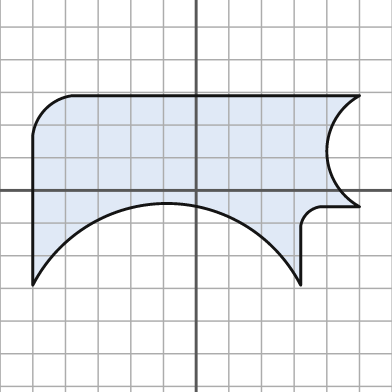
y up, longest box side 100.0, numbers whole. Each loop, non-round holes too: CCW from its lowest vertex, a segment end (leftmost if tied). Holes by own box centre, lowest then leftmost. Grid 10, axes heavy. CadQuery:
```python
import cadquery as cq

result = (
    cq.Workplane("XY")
    .moveTo(-50.0, -29.0)
    .threePointArc((-9.0, -4.0), (32.0, -29.0))
    .lineTo(32.0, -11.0)
    .threePointArc((34.0, -7.0), (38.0, -5.0))
    .lineTo(50.0, -5.0)
    .threePointArc((40.0, 12.0), (50.0, 29.0))
    .lineTo(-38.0, 29.0)
    .threePointArc((-46.0, 25.0), (-50.0, 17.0))
    .close()
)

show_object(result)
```